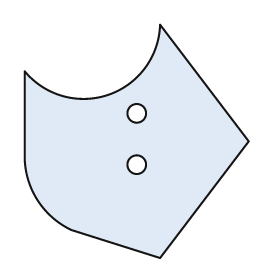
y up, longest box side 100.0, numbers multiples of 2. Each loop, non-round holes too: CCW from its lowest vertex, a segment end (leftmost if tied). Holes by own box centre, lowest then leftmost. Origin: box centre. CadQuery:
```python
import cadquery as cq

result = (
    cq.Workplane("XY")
    .moveTo(10.0, -50.0)
    .lineTo(48.0, 0.0)
    .lineTo(10.0, 50.0)
    .threePointArc((-12.0, 20.0), (-48.0, 30.0))
    .lineTo(-48.0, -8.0)
    .threePointArc((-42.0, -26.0), (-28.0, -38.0))
    .close()
    .moveTo(0.0, -10.0)
    .circle(4.0)
    .moveTo(0.0, 12.0)
    .circle(4.0)
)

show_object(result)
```